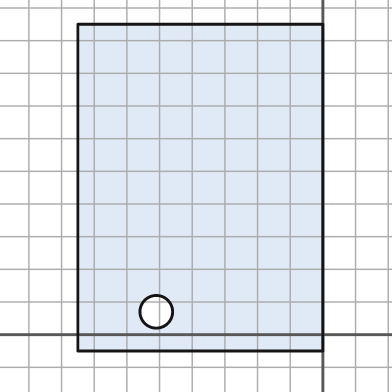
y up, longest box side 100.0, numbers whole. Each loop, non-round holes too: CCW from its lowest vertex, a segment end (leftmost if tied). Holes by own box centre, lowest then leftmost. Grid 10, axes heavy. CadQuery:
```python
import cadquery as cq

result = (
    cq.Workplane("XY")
    .moveTo(-75.0, -5.0)
    .lineTo(0.0, -5.0)
    .lineTo(0.0, 95.0)
    .lineTo(-75.0, 95.0)
    .close()
    .moveTo(-51.0, 7.0)
    .circle(5.0)
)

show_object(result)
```